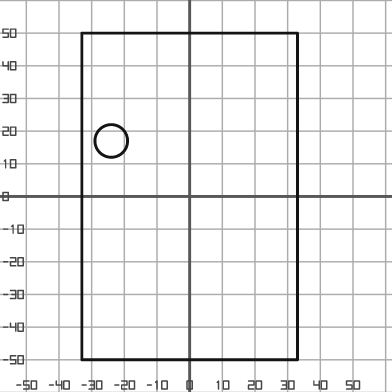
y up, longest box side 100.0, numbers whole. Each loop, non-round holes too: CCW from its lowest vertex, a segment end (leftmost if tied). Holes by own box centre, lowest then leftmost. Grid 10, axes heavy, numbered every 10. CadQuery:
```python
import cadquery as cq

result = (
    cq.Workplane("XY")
    .moveTo(-33.0, -50.0)
    .lineTo(33.0, -50.0)
    .lineTo(33.0, 50.0)
    .lineTo(-33.0, 50.0)
    .close()
    .moveTo(-24.0, 17.0)
    .circle(5.0)
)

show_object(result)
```